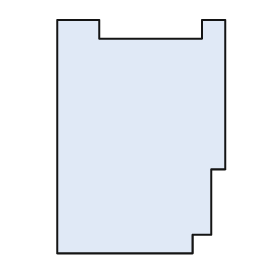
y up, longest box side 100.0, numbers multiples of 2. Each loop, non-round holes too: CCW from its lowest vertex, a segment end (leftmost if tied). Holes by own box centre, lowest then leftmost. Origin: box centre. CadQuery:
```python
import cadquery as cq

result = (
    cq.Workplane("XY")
    .moveTo(-36.0, -50.0)
    .lineTo(22.0, -50.0)
    .lineTo(22.0, -42.0)
    .lineTo(30.0, -42.0)
    .lineTo(30.0, -14.0)
    .lineTo(36.0, -14.0)
    .lineTo(36.0, 50.0)
    .lineTo(26.0, 50.0)
    .lineTo(26.0, 42.0)
    .lineTo(-18.0, 42.0)
    .lineTo(-18.0, 50.0)
    .lineTo(-36.0, 50.0)
    .close()
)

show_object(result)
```